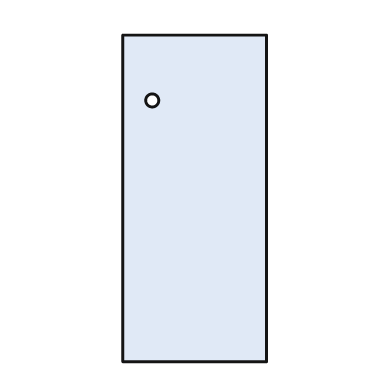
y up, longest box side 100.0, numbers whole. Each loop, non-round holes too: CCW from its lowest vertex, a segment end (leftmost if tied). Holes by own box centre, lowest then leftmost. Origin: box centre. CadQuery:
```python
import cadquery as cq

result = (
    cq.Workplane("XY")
    .moveTo(-22.0, -50.0)
    .lineTo(22.0, -50.0)
    .lineTo(22.0, 50.0)
    .lineTo(-22.0, 50.0)
    .close()
    .moveTo(-13.0, 30.0)
    .circle(2.0)
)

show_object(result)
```